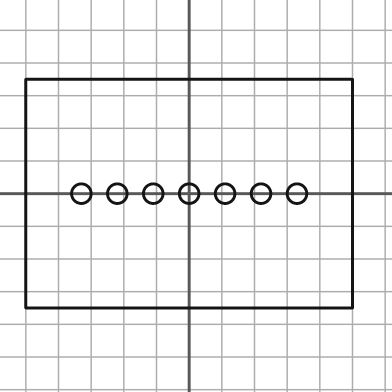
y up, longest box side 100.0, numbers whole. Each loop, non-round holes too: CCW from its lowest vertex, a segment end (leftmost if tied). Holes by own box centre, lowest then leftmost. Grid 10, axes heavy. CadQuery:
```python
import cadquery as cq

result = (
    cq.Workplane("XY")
    .moveTo(-50.0, -35.0)
    .lineTo(50.0, -35.0)
    .lineTo(50.0, 35.0)
    .lineTo(-50.0, 35.0)
    .close()
    .moveTo(-33.0, 0.0)
    .circle(3.0)
    .moveTo(-22.0, 0.0)
    .circle(3.0)
    .moveTo(-11.0, 0.0)
    .circle(3.0)
    .moveTo(0.0, 0.0)
    .circle(3.0)
    .moveTo(11.0, 0.0)
    .circle(3.0)
    .moveTo(22.0, 0.0)
    .circle(3.0)
    .moveTo(33.0, 0.0)
    .circle(3.0)
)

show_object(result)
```